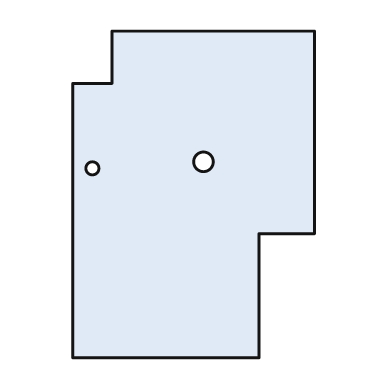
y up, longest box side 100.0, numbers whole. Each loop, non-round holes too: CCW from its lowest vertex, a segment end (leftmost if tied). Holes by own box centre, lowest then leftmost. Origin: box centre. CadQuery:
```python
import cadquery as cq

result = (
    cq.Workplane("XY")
    .moveTo(-37.0, -50.0)
    .lineTo(20.0, -50.0)
    .lineTo(20.0, -12.0)
    .lineTo(37.0, -12.0)
    .lineTo(37.0, 50.0)
    .lineTo(-25.0, 50.0)
    .lineTo(-25.0, 34.0)
    .lineTo(-37.0, 34.0)
    .close()
    .moveTo(-31.0, 8.0)
    .circle(2.0)
    .moveTo(3.0, 10.0)
    .circle(3.0)
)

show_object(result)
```